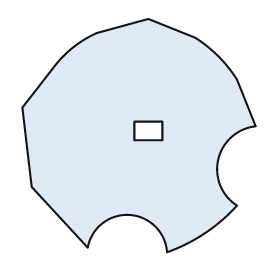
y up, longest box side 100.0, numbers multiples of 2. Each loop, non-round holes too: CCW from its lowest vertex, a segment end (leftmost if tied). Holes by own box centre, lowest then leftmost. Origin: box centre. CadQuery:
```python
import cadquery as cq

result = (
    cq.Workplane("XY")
    .moveTo(12.0, -50.0)
    .threePointArc((28.0, -42.0), (42.0, -30.0))
    .threePointArc((34.0, -10.0), (50.0, 4.0))
    .lineTo(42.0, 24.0)
    .threePointArc((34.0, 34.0), (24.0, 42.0))
    .lineTo(4.0, 50.0)
    .lineTo(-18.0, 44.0)
    .threePointArc((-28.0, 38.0), (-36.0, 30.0))
    .lineTo(-50.0, 12.0)
    .lineTo(-46.0, -22.0)
    .lineTo(-22.0, -48.0)
    .threePointArc((-4.0, -34.0), (12.0, -50.0))
    .close()
    .moveTo(-2.0, -2.0)
    .lineTo(10.0, -2.0)
    .lineTo(10.0, 6.0)
    .lineTo(-2.0, 6.0)
    .close()
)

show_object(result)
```